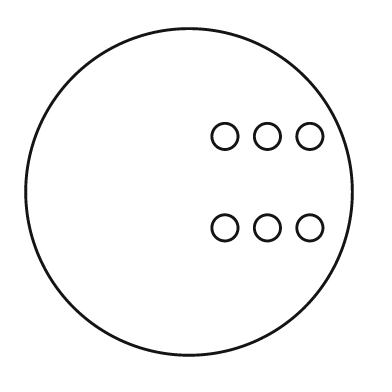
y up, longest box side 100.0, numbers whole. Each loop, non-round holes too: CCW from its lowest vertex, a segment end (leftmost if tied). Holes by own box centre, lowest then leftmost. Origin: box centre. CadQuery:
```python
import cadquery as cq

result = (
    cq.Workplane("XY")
    .moveTo(0.0, 0.0)
    .circle(50.0)
    .moveTo(11.0, -11.0)
    .circle(4.0)
    .moveTo(24.0, -11.0)
    .circle(4.0)
    .moveTo(37.0, -11.0)
    .circle(4.0)
    .moveTo(11.0, 17.0)
    .circle(4.0)
    .moveTo(24.0, 17.0)
    .circle(4.0)
    .moveTo(37.0, 17.0)
    .circle(4.0)
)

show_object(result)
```